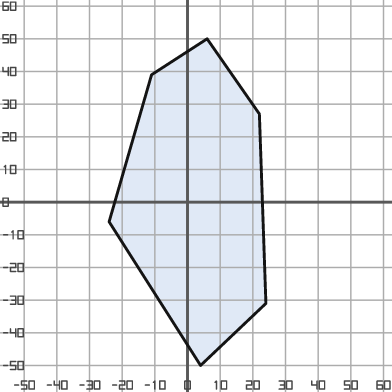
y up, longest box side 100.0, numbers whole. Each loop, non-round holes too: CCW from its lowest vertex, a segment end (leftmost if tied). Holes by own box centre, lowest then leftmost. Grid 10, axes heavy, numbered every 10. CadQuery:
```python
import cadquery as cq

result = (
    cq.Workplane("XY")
    .moveTo(4.0, -50.0)
    .lineTo(24.0, -31.0)
    .lineTo(22.0, 27.0)
    .lineTo(6.0, 50.0)
    .lineTo(-11.0, 39.0)
    .lineTo(-24.0, -6.0)
    .close()
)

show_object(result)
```